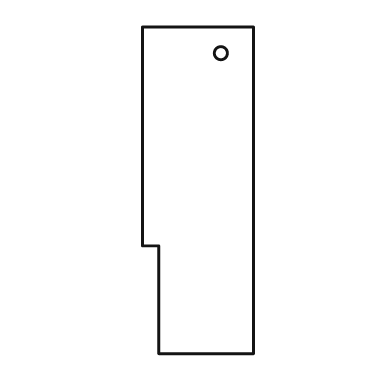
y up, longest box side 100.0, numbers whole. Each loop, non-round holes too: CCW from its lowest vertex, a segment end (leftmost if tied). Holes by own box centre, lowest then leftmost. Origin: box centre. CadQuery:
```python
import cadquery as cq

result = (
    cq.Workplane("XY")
    .moveTo(-12.0, -50.0)
    .lineTo(17.0, -50.0)
    .lineTo(17.0, 50.0)
    .lineTo(-17.0, 50.0)
    .lineTo(-17.0, -17.0)
    .lineTo(-12.0, -17.0)
    .close()
    .moveTo(7.0, 42.0)
    .circle(2.0)
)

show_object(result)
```